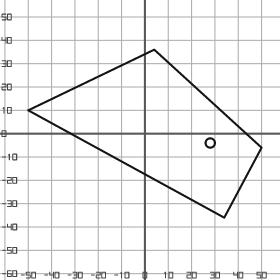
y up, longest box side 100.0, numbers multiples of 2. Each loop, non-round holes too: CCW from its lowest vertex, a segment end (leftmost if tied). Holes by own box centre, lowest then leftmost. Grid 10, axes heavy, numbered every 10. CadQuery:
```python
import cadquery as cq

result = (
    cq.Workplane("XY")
    .moveTo(34.0, -36.0)
    .lineTo(50.0, -6.0)
    .lineTo(4.0, 36.0)
    .lineTo(-50.0, 10.0)
    .close()
    .moveTo(28.0, -4.0)
    .circle(2.0)
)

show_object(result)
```